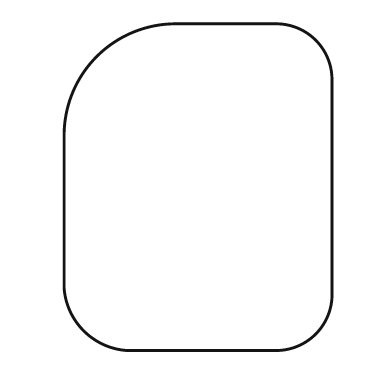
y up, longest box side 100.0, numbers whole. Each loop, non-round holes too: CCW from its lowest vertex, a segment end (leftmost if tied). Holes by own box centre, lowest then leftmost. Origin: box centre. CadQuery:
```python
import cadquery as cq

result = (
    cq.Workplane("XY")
    .moveTo(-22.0, -50.0)
    .lineTo(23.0, -50.0)
    .threePointArc((36.0, -45.0), (41.0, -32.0))
    .lineTo(41.0, 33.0)
    .threePointArc((36.0, 45.0), (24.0, 50.0))
    .lineTo(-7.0, 50.0)
    .threePointArc((-31.0, 40.0), (-41.0, 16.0))
    .lineTo(-41.0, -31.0)
    .threePointArc((-35.0, -44.0), (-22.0, -50.0))
    .close()
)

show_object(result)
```